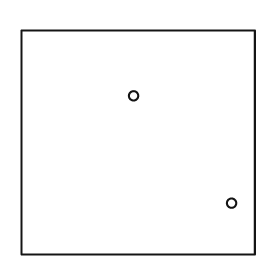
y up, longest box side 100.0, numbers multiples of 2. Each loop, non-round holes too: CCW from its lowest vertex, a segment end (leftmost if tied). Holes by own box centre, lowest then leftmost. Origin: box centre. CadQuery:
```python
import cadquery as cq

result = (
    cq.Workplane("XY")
    .moveTo(-50.0, -48.0)
    .lineTo(50.0, -48.0)
    .lineTo(50.0, 48.0)
    .lineTo(-50.0, 48.0)
    .close()
    .moveTo(40.0, -26.0)
    .circle(2.0)
    .moveTo(-2.0, 20.0)
    .circle(2.0)
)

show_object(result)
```